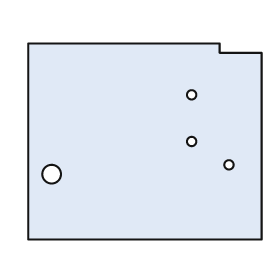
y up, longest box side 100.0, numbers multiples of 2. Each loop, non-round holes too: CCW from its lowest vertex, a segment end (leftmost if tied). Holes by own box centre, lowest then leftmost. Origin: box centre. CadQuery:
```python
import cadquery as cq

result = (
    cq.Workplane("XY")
    .moveTo(-50.0, -42.0)
    .lineTo(50.0, -42.0)
    .lineTo(50.0, 38.0)
    .lineTo(32.0, 38.0)
    .lineTo(32.0, 42.0)
    .lineTo(-50.0, 42.0)
    .close()
    .moveTo(-40.0, -14.0)
    .circle(4.0)
    .moveTo(36.0, -10.0)
    .circle(2.0)
    .moveTo(20.0, 0.0)
    .circle(2.0)
    .moveTo(20.0, 20.0)
    .circle(2.0)
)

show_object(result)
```